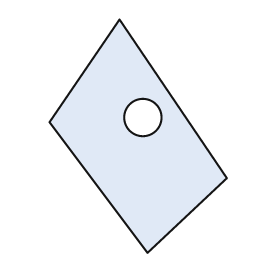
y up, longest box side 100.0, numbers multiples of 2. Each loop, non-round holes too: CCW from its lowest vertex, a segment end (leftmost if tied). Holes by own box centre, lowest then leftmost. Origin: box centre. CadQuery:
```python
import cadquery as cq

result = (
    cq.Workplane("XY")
    .moveTo(4.0, -50.0)
    .lineTo(38.0, -18.0)
    .lineTo(-8.0, 50.0)
    .lineTo(-38.0, 6.0)
    .close()
    .moveTo(2.0, 8.0)
    .circle(8.0)
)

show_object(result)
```